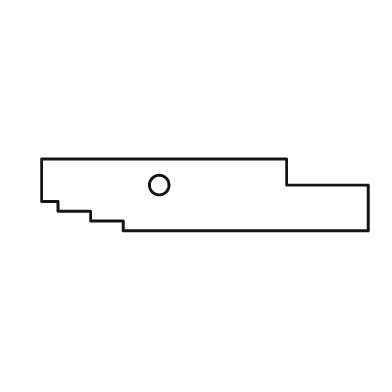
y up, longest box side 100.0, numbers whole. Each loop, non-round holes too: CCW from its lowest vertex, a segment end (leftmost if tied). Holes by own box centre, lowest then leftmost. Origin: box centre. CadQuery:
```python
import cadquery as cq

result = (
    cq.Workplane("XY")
    .moveTo(-25.0, -11.0)
    .lineTo(50.0, -11.0)
    .lineTo(50.0, 3.0)
    .lineTo(25.0, 3.0)
    .lineTo(25.0, 11.0)
    .lineTo(-50.0, 11.0)
    .lineTo(-50.0, -2.0)
    .lineTo(-45.0, -2.0)
    .lineTo(-45.0, -5.0)
    .lineTo(-35.0, -5.0)
    .lineTo(-35.0, -8.0)
    .lineTo(-25.0, -8.0)
    .close()
    .moveTo(-14.0, 3.0)
    .circle(3.0)
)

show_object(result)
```